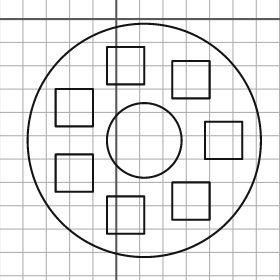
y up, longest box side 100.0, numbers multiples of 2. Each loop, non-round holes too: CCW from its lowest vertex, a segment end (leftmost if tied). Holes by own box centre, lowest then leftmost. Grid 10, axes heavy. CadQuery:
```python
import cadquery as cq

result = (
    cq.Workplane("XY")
    .moveTo(12.0, -52.0)
    .circle(50.0)
    .moveTo(-4.0, -92.0)
    .lineTo(12.0, -92.0)
    .lineTo(12.0, -76.0)
    .lineTo(-4.0, -76.0)
    .close()
    .moveTo(24.0, -86.0)
    .lineTo(40.0, -86.0)
    .lineTo(40.0, -70.0)
    .lineTo(24.0, -70.0)
    .close()
    .moveTo(-26.0, -74.0)
    .lineTo(-10.0, -74.0)
    .lineTo(-10.0, -58.0)
    .lineTo(-26.0, -58.0)
    .close()
    .moveTo(12.0, -52.0)
    .circle(16.0)
    .moveTo(38.0, -60.0)
    .lineTo(54.0, -60.0)
    .lineTo(54.0, -44.0)
    .lineTo(38.0, -44.0)
    .close()
    .moveTo(-26.0, -46.0)
    .lineTo(-10.0, -46.0)
    .lineTo(-10.0, -30.0)
    .lineTo(-26.0, -30.0)
    .close()
    .moveTo(24.0, -34.0)
    .lineTo(40.0, -34.0)
    .lineTo(40.0, -18.0)
    .lineTo(24.0, -18.0)
    .close()
    .moveTo(-4.0, -28.0)
    .lineTo(12.0, -28.0)
    .lineTo(12.0, -12.0)
    .lineTo(-4.0, -12.0)
    .close()
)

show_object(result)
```